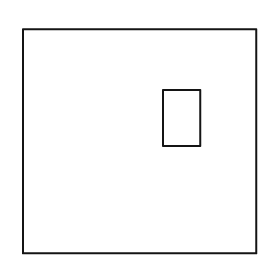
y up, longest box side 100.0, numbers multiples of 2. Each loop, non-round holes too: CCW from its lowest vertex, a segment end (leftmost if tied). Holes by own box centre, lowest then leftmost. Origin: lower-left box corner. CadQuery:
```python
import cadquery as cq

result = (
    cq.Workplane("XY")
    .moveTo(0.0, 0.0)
    .lineTo(100.0, 0.0)
    .lineTo(100.0, 96.0)
    .lineTo(0.0, 96.0)
    .close()
    .moveTo(60.0, 46.0)
    .lineTo(76.0, 46.0)
    .lineTo(76.0, 70.0)
    .lineTo(60.0, 70.0)
    .close()
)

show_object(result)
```